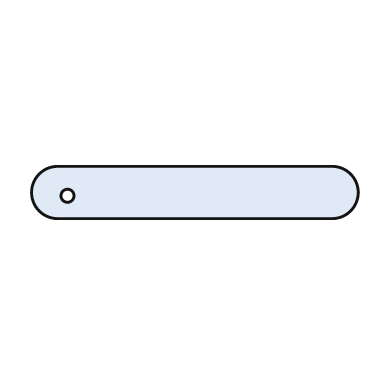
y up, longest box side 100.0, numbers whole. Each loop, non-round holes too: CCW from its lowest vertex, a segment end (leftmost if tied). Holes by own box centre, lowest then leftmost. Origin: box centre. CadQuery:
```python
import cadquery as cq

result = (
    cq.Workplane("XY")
    .moveTo(-42.0, -8.0)
    .lineTo(42.0, -8.0)
    .threePointArc((50.0, 0.0), (42.0, 8.0))
    .lineTo(-42.0, 8.0)
    .threePointArc((-50.0, 0.0), (-42.0, -8.0))
    .close()
    .moveTo(-39.0, -1.0)
    .circle(2.0)
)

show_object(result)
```